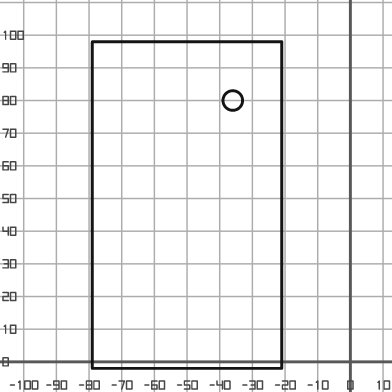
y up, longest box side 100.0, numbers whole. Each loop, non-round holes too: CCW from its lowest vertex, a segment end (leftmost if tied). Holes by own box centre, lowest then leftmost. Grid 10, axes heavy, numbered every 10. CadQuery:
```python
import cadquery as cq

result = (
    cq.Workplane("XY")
    .moveTo(-79.0, -2.0)
    .lineTo(-21.0, -2.0)
    .lineTo(-21.0, 98.0)
    .lineTo(-79.0, 98.0)
    .close()
    .moveTo(-36.0, 80.0)
    .circle(3.0)
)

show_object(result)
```